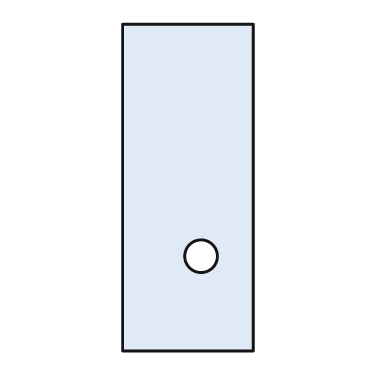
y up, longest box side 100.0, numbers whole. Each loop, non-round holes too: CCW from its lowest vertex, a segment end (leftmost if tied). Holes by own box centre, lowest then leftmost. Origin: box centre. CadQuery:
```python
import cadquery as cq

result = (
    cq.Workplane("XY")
    .moveTo(-20.0, -50.0)
    .lineTo(20.0, -50.0)
    .lineTo(20.0, 50.0)
    .lineTo(-20.0, 50.0)
    .close()
    .moveTo(4.0, -21.0)
    .circle(5.0)
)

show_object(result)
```